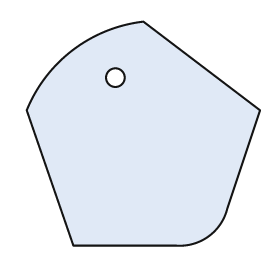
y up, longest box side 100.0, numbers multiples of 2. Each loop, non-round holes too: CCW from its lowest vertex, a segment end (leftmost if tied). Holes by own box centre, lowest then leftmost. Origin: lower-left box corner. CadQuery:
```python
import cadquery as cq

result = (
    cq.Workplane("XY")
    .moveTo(20.0, 0.0)
    .lineTo(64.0, 0.0)
    .threePointArc((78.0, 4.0), (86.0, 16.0))
    .lineTo(100.0, 58.0)
    .lineTo(50.0, 96.0)
    .threePointArc((20.0, 84.0), (0.0, 58.0))
    .close()
    .moveTo(38.0, 72.0)
    .circle(4.0)
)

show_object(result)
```